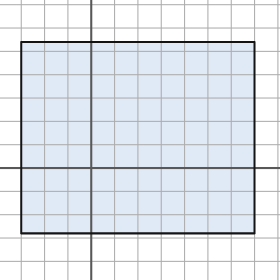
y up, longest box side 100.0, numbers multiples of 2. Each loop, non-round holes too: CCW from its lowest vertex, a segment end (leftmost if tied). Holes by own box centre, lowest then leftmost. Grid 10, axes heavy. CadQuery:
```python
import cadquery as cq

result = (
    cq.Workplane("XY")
    .moveTo(-30.0, -28.0)
    .lineTo(70.0, -28.0)
    .lineTo(70.0, 54.0)
    .lineTo(-30.0, 54.0)
    .close()
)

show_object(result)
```